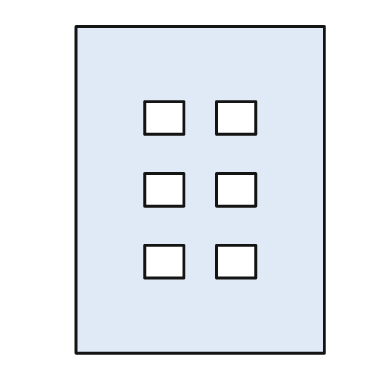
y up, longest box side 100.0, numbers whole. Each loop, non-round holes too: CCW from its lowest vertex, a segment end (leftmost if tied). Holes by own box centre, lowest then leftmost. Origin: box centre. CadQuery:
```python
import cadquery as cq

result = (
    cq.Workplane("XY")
    .moveTo(-38.0, -50.0)
    .lineTo(38.0, -50.0)
    .lineTo(38.0, 50.0)
    .lineTo(-38.0, 50.0)
    .close()
    .moveTo(-17.0, -27.0)
    .lineTo(-5.0, -27.0)
    .lineTo(-5.0, -17.0)
    .lineTo(-17.0, -17.0)
    .close()
    .moveTo(5.0, -27.0)
    .lineTo(17.0, -27.0)
    .lineTo(17.0, -17.0)
    .lineTo(5.0, -17.0)
    .close()
    .moveTo(-17.0, -5.0)
    .lineTo(-5.0, -5.0)
    .lineTo(-5.0, 5.0)
    .lineTo(-17.0, 5.0)
    .close()
    .moveTo(5.0, -5.0)
    .lineTo(17.0, -5.0)
    .lineTo(17.0, 5.0)
    .lineTo(5.0, 5.0)
    .close()
    .moveTo(-17.0, 17.0)
    .lineTo(-5.0, 17.0)
    .lineTo(-5.0, 27.0)
    .lineTo(-17.0, 27.0)
    .close()
    .moveTo(5.0, 17.0)
    .lineTo(17.0, 17.0)
    .lineTo(17.0, 27.0)
    .lineTo(5.0, 27.0)
    .close()
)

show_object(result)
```